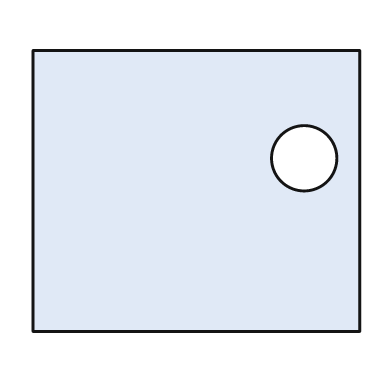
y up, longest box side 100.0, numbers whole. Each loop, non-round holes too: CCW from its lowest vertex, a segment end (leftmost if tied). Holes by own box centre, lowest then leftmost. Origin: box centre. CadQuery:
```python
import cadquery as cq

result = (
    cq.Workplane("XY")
    .moveTo(-50.0, -43.0)
    .lineTo(50.0, -43.0)
    .lineTo(50.0, 43.0)
    .lineTo(-50.0, 43.0)
    .close()
    .moveTo(33.0, 10.0)
    .circle(10.0)
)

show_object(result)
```